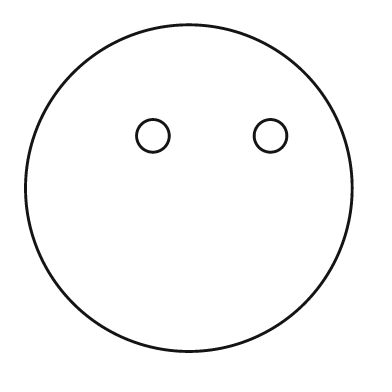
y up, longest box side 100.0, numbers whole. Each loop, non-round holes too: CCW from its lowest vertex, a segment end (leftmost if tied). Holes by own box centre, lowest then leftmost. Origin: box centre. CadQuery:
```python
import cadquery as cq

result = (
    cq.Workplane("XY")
    .moveTo(0.0, 0.0)
    .circle(50.0)
    .moveTo(-11.0, 16.0)
    .circle(5.0)
    .moveTo(25.0, 16.0)
    .circle(5.0)
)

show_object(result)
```